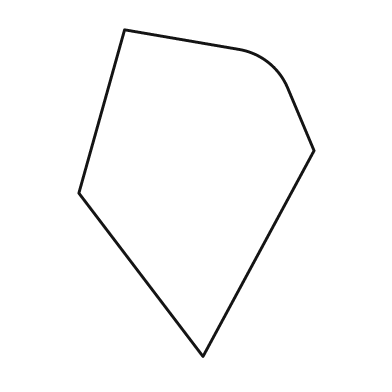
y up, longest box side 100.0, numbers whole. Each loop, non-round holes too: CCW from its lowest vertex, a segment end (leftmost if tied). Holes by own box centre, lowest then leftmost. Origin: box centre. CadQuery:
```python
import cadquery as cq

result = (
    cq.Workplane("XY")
    .moveTo(2.0, -50.0)
    .lineTo(36.0, 13.0)
    .lineTo(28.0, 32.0)
    .threePointArc((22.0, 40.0), (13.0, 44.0))
    .lineTo(-22.0, 50.0)
    .lineTo(-36.0, 0.0)
    .close()
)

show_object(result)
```